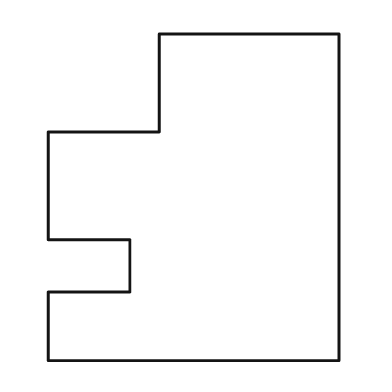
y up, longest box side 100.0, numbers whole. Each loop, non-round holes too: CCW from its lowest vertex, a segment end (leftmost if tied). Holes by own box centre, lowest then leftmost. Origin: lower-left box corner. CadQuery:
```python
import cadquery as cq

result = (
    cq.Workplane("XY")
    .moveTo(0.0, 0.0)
    .lineTo(89.0, 0.0)
    .lineTo(89.0, 100.0)
    .lineTo(34.0, 100.0)
    .lineTo(34.0, 70.0)
    .lineTo(0.0, 70.0)
    .lineTo(0.0, 37.0)
    .lineTo(25.0, 37.0)
    .lineTo(25.0, 21.0)
    .lineTo(0.0, 21.0)
    .close()
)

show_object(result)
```